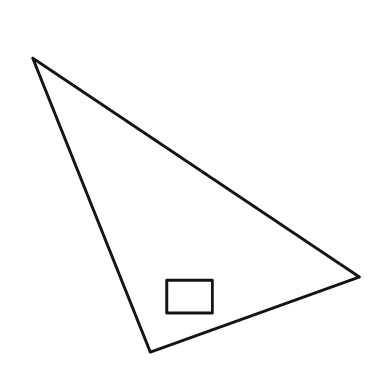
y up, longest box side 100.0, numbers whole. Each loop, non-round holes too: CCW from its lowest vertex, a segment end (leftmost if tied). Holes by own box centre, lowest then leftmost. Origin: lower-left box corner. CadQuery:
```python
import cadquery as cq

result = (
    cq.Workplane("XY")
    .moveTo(36.0, 0.0)
    .lineTo(100.0, 23.0)
    .lineTo(0.0, 90.0)
    .close()
    .moveTo(41.0, 12.0)
    .lineTo(55.0, 12.0)
    .lineTo(55.0, 22.0)
    .lineTo(41.0, 22.0)
    .close()
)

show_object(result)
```